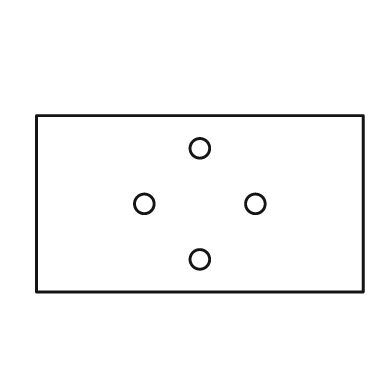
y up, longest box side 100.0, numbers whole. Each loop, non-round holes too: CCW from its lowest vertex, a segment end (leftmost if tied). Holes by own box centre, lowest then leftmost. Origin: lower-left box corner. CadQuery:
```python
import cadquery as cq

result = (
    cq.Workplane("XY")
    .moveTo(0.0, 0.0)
    .lineTo(100.0, 0.0)
    .lineTo(100.0, 54.0)
    .lineTo(0.0, 54.0)
    .close()
    .moveTo(50.0, 10.0)
    .circle(3.0)
    .moveTo(33.0, 27.0)
    .circle(3.0)
    .moveTo(67.0, 27.0)
    .circle(3.0)
    .moveTo(50.0, 44.0)
    .circle(3.0)
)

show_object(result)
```